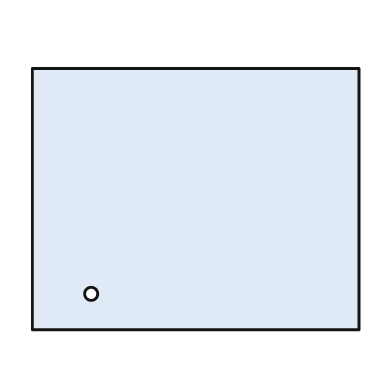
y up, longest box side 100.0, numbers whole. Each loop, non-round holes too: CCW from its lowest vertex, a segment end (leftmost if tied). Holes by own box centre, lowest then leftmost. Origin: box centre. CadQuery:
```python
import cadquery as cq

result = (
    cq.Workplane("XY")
    .moveTo(-50.0, -40.0)
    .lineTo(50.0, -40.0)
    .lineTo(50.0, 40.0)
    .lineTo(-50.0, 40.0)
    .close()
    .moveTo(-32.0, -29.0)
    .circle(2.0)
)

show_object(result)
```